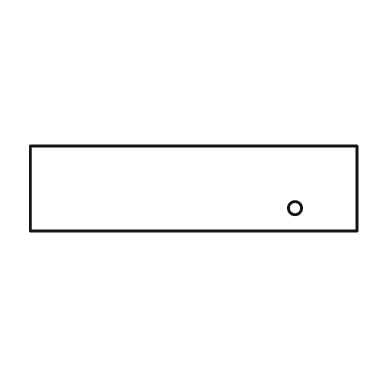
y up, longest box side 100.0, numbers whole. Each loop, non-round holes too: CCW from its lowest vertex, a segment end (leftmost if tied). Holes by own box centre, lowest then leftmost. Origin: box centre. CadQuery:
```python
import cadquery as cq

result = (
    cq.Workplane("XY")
    .moveTo(-50.0, -13.0)
    .lineTo(50.0, -13.0)
    .lineTo(50.0, 13.0)
    .lineTo(-50.0, 13.0)
    .close()
    .moveTo(31.0, -6.0)
    .circle(2.0)
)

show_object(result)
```